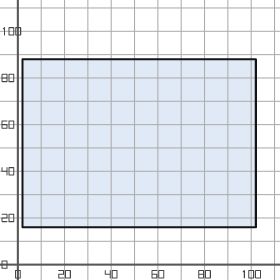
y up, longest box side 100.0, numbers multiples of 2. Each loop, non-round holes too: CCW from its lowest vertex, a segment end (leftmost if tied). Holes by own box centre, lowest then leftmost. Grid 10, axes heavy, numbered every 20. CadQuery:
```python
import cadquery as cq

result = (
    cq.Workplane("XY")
    .moveTo(2.0, 16.0)
    .lineTo(102.0, 16.0)
    .lineTo(102.0, 88.0)
    .lineTo(2.0, 88.0)
    .close()
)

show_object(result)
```